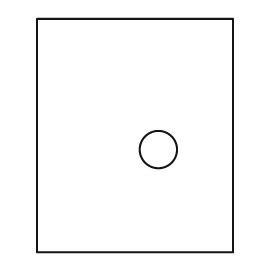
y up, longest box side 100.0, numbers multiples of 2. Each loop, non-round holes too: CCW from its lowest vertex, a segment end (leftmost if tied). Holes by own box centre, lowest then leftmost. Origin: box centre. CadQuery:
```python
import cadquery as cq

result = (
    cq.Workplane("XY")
    .moveTo(-42.0, -50.0)
    .lineTo(42.0, -50.0)
    .lineTo(42.0, 50.0)
    .lineTo(-42.0, 50.0)
    .close()
    .moveTo(10.0, -6.0)
    .circle(8.0)
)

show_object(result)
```